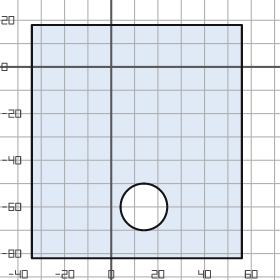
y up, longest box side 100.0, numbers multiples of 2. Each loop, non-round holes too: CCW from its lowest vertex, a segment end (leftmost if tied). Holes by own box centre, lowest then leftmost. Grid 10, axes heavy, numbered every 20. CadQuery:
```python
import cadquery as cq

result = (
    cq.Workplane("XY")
    .moveTo(-34.0, -82.0)
    .lineTo(56.0, -82.0)
    .lineTo(56.0, 18.0)
    .lineTo(-34.0, 18.0)
    .close()
    .moveTo(14.0, -60.0)
    .circle(10.0)
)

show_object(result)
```